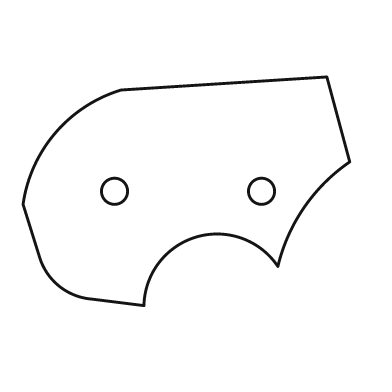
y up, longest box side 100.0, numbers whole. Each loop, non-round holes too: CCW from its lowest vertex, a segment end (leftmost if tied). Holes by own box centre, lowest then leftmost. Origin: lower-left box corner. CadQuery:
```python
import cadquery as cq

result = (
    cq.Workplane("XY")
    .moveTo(37.0, 0.0)
    .threePointArc((53.0, 21.0), (78.0, 12.0))
    .threePointArc((86.0, 30.0), (100.0, 44.0))
    .lineTo(93.0, 70.0)
    .lineTo(30.0, 66.0)
    .threePointArc((10.0, 53.0), (0.0, 31.0))
    .lineTo(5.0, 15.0)
    .threePointArc((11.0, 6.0), (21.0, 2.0))
    .close()
    .moveTo(28.0, 35.0)
    .circle(4.0)
    .moveTo(73.0, 35.0)
    .circle(4.0)
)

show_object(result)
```